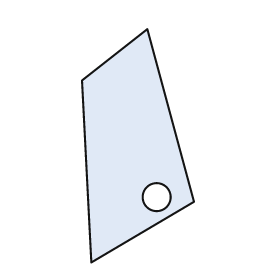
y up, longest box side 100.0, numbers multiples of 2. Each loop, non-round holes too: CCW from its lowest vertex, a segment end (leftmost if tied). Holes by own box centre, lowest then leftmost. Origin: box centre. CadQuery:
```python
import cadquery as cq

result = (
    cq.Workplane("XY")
    .moveTo(-20.0, -50.0)
    .lineTo(24.0, -24.0)
    .lineTo(4.0, 50.0)
    .lineTo(-24.0, 28.0)
    .close()
    .moveTo(8.0, -22.0)
    .circle(6.0)
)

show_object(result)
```